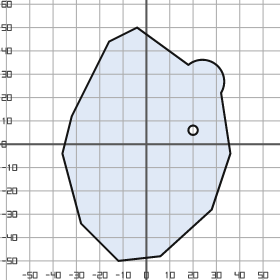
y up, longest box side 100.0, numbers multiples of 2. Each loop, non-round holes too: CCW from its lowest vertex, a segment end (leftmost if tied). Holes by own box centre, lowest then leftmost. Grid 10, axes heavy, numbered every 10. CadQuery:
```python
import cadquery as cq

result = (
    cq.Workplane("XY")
    .moveTo(-12.0, -50.0)
    .lineTo(6.0, -48.0)
    .lineTo(28.0, -28.0)
    .lineTo(36.0, -4.0)
    .lineTo(32.0, 22.0)
    .threePointArc((30.0, 34.0), (18.0, 34.0))
    .lineTo(-4.0, 50.0)
    .lineTo(-16.0, 44.0)
    .lineTo(-32.0, 12.0)
    .lineTo(-36.0, -4.0)
    .lineTo(-28.0, -34.0)
    .close()
    .moveTo(20.0, 6.0)
    .circle(2.0)
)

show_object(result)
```